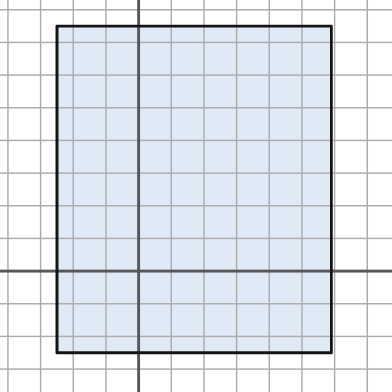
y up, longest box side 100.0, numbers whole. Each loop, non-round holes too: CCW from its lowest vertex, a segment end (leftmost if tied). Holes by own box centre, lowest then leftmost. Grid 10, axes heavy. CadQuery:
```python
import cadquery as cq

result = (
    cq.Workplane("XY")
    .moveTo(-25.0, -25.0)
    .lineTo(59.0, -25.0)
    .lineTo(59.0, 75.0)
    .lineTo(-25.0, 75.0)
    .close()
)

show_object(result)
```